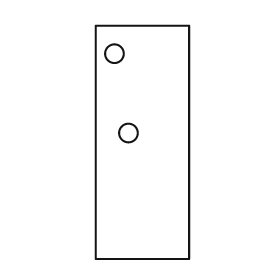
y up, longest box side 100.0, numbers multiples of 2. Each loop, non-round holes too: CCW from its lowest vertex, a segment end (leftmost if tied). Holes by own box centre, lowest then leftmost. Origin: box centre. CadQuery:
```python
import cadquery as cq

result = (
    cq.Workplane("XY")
    .moveTo(-20.0, -50.0)
    .lineTo(20.0, -50.0)
    .lineTo(20.0, 50.0)
    .lineTo(-20.0, 50.0)
    .close()
    .moveTo(-6.0, 4.0)
    .circle(4.0)
    .moveTo(-12.0, 38.0)
    .circle(4.0)
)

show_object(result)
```